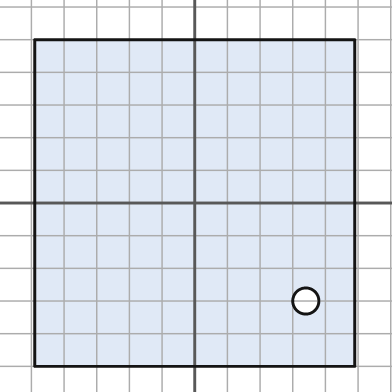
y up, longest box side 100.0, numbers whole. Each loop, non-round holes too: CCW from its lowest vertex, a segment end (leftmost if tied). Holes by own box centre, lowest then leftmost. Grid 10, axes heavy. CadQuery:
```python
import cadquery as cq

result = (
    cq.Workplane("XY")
    .moveTo(-49.0, -50.0)
    .lineTo(49.0, -50.0)
    .lineTo(49.0, 50.0)
    .lineTo(-49.0, 50.0)
    .close()
    .moveTo(34.0, -30.0)
    .circle(4.0)
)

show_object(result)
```